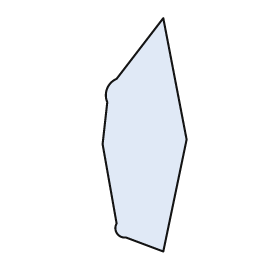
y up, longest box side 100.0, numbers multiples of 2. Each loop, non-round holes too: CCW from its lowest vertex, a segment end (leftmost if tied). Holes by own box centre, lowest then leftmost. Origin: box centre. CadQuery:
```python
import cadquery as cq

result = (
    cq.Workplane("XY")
    .moveTo(8.0, -50.0)
    .lineTo(18.0, -2.0)
    .lineTo(8.0, 50.0)
    .lineTo(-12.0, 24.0)
    .threePointArc((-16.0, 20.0), (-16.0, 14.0))
    .lineTo(-18.0, -4.0)
    .lineTo(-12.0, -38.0)
    .threePointArc((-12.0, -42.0), (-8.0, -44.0))
    .close()
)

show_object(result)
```